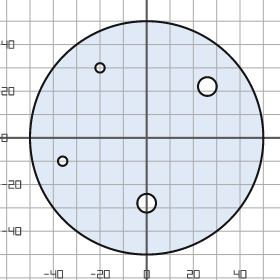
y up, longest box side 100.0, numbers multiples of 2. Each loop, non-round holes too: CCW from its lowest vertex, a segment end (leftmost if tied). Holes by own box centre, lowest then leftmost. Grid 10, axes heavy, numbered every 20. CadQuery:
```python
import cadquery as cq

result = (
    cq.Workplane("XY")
    .moveTo(0.0, 0.0)
    .circle(50.0)
    .moveTo(0.0, -28.0)
    .circle(4.0)
    .moveTo(-36.0, -10.0)
    .circle(2.0)
    .moveTo(26.0, 22.0)
    .circle(4.0)
    .moveTo(-20.0, 30.0)
    .circle(2.0)
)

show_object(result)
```